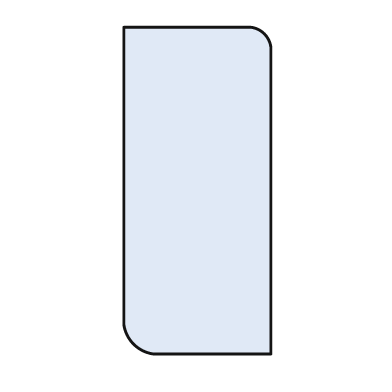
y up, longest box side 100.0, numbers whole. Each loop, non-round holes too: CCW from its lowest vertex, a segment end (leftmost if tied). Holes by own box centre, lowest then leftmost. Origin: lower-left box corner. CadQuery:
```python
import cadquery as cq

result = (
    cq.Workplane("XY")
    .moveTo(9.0, 0.0)
    .lineTo(45.0, 0.0)
    .lineTo(45.0, 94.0)
    .threePointArc((43.0, 98.0), (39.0, 100.0))
    .lineTo(0.0, 100.0)
    .lineTo(0.0, 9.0)
    .threePointArc((3.0, 3.0), (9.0, 0.0))
    .close()
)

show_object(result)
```